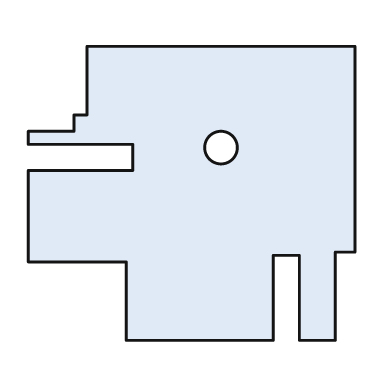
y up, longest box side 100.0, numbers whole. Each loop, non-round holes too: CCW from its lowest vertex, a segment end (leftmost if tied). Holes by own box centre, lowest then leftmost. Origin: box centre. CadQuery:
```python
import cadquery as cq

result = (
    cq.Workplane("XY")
    .moveTo(-20.0, -45.0)
    .lineTo(25.0, -45.0)
    .lineTo(25.0, -19.0)
    .lineTo(33.0, -19.0)
    .lineTo(33.0, -45.0)
    .lineTo(44.0, -45.0)
    .lineTo(44.0, -18.0)
    .lineTo(50.0, -18.0)
    .lineTo(50.0, 45.0)
    .lineTo(-32.0, 45.0)
    .lineTo(-32.0, 24.0)
    .lineTo(-36.0, 24.0)
    .lineTo(-36.0, 19.0)
    .lineTo(-50.0, 19.0)
    .lineTo(-50.0, 15.0)
    .lineTo(-18.0, 15.0)
    .lineTo(-18.0, 7.0)
    .lineTo(-50.0, 7.0)
    .lineTo(-50.0, -21.0)
    .lineTo(-20.0, -21.0)
    .close()
    .moveTo(9.0, 14.0)
    .circle(5.0)
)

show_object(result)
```